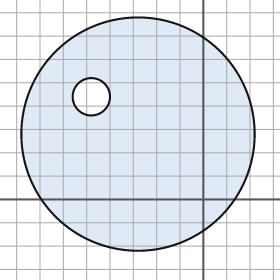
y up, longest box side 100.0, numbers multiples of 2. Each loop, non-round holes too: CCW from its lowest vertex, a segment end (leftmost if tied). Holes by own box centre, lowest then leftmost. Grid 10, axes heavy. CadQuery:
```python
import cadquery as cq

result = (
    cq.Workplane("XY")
    .moveTo(-28.0, 28.0)
    .circle(50.0)
    .moveTo(-48.0, 44.0)
    .circle(8.0)
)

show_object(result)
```